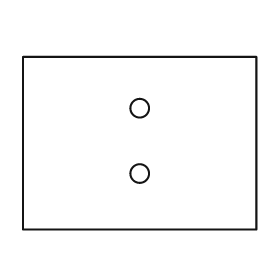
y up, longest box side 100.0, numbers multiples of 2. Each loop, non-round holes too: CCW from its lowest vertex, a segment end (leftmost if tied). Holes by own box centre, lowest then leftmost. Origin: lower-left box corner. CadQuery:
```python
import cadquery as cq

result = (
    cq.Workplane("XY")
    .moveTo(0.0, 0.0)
    .lineTo(100.0, 0.0)
    .lineTo(100.0, 74.0)
    .lineTo(0.0, 74.0)
    .close()
    .moveTo(50.0, 24.0)
    .circle(4.0)
    .moveTo(50.0, 52.0)
    .circle(4.0)
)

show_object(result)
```